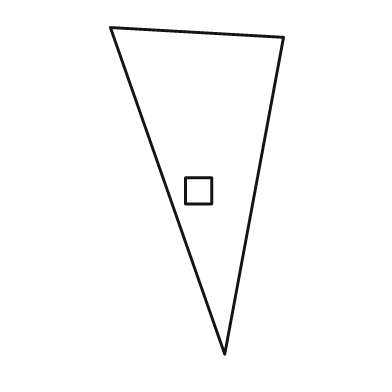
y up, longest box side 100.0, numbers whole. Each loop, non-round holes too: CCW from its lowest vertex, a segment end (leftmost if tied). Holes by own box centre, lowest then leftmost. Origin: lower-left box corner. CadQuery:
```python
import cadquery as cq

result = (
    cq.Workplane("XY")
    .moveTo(35.0, 0.0)
    .lineTo(53.0, 97.0)
    .lineTo(0.0, 100.0)
    .close()
    .moveTo(23.0, 46.0)
    .lineTo(31.0, 46.0)
    .lineTo(31.0, 54.0)
    .lineTo(23.0, 54.0)
    .close()
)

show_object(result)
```